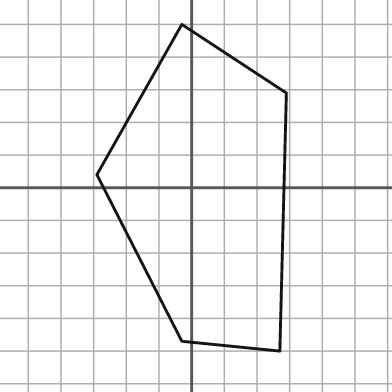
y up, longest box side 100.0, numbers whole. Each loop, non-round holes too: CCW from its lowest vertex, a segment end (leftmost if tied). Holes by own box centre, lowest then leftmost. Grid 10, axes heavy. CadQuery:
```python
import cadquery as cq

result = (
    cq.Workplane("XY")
    .moveTo(27.0, -50.0)
    .lineTo(29.0, 29.0)
    .lineTo(-3.0, 50.0)
    .lineTo(-29.0, 4.0)
    .lineTo(-3.0, -47.0)
    .close()
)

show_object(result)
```